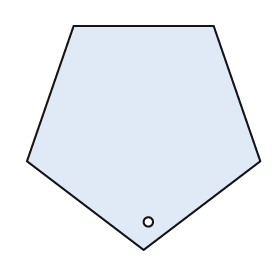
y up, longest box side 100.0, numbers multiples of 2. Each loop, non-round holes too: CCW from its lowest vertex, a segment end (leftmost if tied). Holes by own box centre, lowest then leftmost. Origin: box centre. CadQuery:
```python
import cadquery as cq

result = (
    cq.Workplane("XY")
    .moveTo(0.0, -48.0)
    .lineTo(50.0, -10.0)
    .lineTo(30.0, 48.0)
    .lineTo(-30.0, 48.0)
    .lineTo(-50.0, -10.0)
    .close()
    .moveTo(2.0, -36.0)
    .circle(2.0)
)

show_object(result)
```